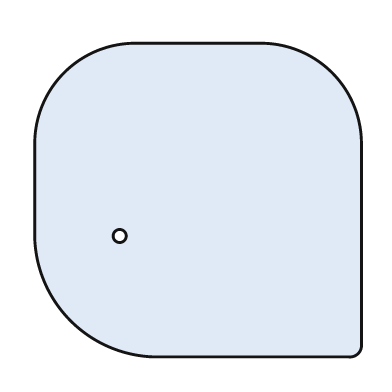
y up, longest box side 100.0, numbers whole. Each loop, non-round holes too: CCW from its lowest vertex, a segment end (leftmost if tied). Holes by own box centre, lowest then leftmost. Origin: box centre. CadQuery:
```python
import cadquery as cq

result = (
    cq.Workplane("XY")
    .moveTo(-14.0, -48.0)
    .lineTo(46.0, -48.0)
    .threePointArc((49.0, -47.0), (50.0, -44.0))
    .lineTo(50.0, 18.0)
    .threePointArc((41.0, 39.0), (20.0, 48.0))
    .lineTo(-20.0, 48.0)
    .threePointArc((-41.0, 39.0), (-50.0, 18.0))
    .lineTo(-50.0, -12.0)
    .threePointArc((-39.0, -37.0), (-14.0, -48.0))
    .close()
    .moveTo(-24.0, -11.0)
    .circle(2.0)
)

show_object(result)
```